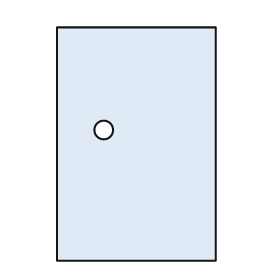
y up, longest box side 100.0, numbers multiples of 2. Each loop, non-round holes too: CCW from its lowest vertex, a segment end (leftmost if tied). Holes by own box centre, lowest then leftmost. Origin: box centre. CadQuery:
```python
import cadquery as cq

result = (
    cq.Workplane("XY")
    .moveTo(-34.0, -50.0)
    .lineTo(34.0, -50.0)
    .lineTo(34.0, 50.0)
    .lineTo(-34.0, 50.0)
    .close()
    .moveTo(-14.0, 6.0)
    .circle(4.0)
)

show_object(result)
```